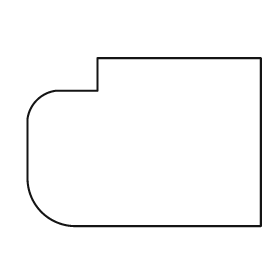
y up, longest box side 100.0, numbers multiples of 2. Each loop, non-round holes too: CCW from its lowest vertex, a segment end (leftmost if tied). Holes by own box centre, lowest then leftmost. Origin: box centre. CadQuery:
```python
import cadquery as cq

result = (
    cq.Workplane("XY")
    .moveTo(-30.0, -36.0)
    .lineTo(50.0, -36.0)
    .lineTo(50.0, 36.0)
    .lineTo(-20.0, 36.0)
    .lineTo(-20.0, 22.0)
    .lineTo(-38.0, 22.0)
    .threePointArc((-46.0, 18.0), (-50.0, 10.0))
    .lineTo(-50.0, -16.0)
    .threePointArc((-44.0, -30.0), (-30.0, -36.0))
    .close()
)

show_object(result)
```